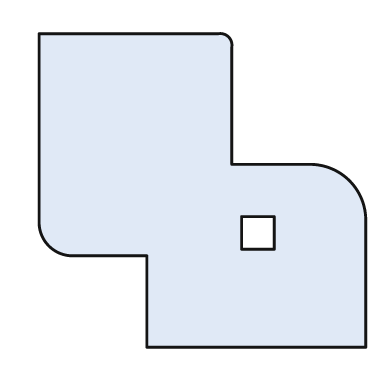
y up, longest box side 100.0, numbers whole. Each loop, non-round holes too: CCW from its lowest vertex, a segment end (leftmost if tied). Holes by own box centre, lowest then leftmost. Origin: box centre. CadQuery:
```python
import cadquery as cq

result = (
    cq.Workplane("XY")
    .moveTo(-17.0, -48.0)
    .lineTo(50.0, -48.0)
    .lineTo(50.0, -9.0)
    .threePointArc((45.0, 3.0), (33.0, 8.0))
    .lineTo(9.0, 8.0)
    .lineTo(9.0, 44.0)
    .threePointArc((8.0, 47.0), (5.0, 48.0))
    .lineTo(-50.0, 48.0)
    .lineTo(-50.0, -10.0)
    .threePointArc((-47.0, -17.0), (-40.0, -20.0))
    .lineTo(-17.0, -20.0)
    .close()
    .moveTo(12.0, -18.0)
    .lineTo(22.0, -18.0)
    .lineTo(22.0, -8.0)
    .lineTo(12.0, -8.0)
    .close()
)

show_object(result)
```